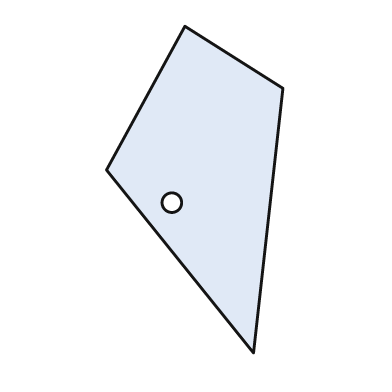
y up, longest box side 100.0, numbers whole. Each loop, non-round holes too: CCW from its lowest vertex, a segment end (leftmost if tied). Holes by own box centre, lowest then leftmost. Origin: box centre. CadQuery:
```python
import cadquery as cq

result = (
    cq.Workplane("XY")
    .moveTo(18.0, -50.0)
    .lineTo(27.0, 31.0)
    .lineTo(-3.0, 50.0)
    .lineTo(-27.0, 6.0)
    .close()
    .moveTo(-7.0, -4.0)
    .circle(3.0)
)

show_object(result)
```